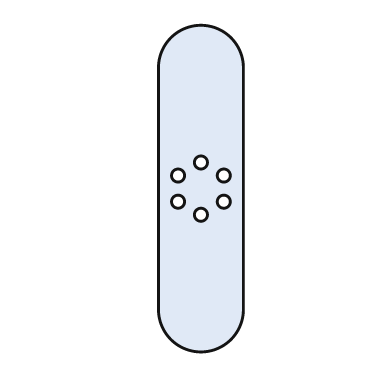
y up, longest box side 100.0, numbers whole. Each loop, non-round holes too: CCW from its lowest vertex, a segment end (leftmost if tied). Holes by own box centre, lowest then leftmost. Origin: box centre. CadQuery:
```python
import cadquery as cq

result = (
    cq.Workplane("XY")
    .moveTo(-13.0, -37.0)
    .threePointArc((0.0, -50.0), (13.0, -37.0))
    .lineTo(13.0, 37.0)
    .threePointArc((0.0, 50.0), (-13.0, 37.0))
    .close()
    .moveTo(0.0, -8.0)
    .circle(2.0)
    .moveTo(-7.0, -4.0)
    .circle(2.0)
    .moveTo(7.0, -4.0)
    .circle(2.0)
    .moveTo(-7.0, 4.0)
    .circle(2.0)
    .moveTo(7.0, 4.0)
    .circle(2.0)
    .moveTo(0.0, 8.0)
    .circle(2.0)
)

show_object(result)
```